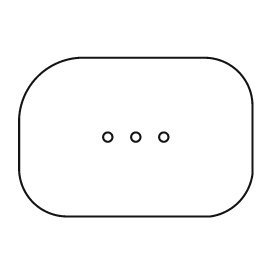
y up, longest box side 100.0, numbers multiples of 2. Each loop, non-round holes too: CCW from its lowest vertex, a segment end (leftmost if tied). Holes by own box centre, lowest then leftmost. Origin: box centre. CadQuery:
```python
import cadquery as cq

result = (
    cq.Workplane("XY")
    .moveTo(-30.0, -34.0)
    .lineTo(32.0, -34.0)
    .threePointArc((44.0, -28.0), (50.0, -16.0))
    .lineTo(50.0, 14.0)
    .threePointArc((44.0, 28.0), (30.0, 34.0))
    .lineTo(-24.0, 34.0)
    .threePointArc((-42.0, 26.0), (-50.0, 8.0))
    .lineTo(-50.0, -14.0)
    .threePointArc((-44.0, -28.0), (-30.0, -34.0))
    .close()
    .moveTo(-12.0, 0.0)
    .circle(2.0)
    .moveTo(0.0, 0.0)
    .circle(2.0)
    .moveTo(12.0, 0.0)
    .circle(2.0)
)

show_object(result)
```